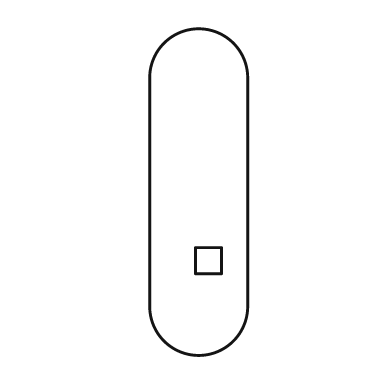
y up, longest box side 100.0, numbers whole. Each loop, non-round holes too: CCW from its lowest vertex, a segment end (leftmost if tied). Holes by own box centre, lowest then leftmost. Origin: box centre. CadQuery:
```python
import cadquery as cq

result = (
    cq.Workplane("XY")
    .moveTo(-15.0, -35.0)
    .threePointArc((0.0, -50.0), (15.0, -35.0))
    .lineTo(15.0, 35.0)
    .threePointArc((0.0, 50.0), (-15.0, 35.0))
    .close()
    .moveTo(-1.0, -25.0)
    .lineTo(7.0, -25.0)
    .lineTo(7.0, -17.0)
    .lineTo(-1.0, -17.0)
    .close()
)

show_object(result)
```